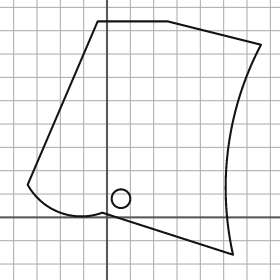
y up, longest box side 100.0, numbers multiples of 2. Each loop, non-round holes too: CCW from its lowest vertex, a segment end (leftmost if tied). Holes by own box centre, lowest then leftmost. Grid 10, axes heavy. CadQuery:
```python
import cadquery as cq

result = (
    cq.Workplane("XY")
    .moveTo(54.0, -16.0)
    .threePointArc((52.0, 30.0), (66.0, 74.0))
    .lineTo(26.0, 84.0)
    .lineTo(-4.0, 84.0)
    .lineTo(-34.0, 14.0)
    .threePointArc((-20.0, 2.0), (-2.0, 2.0))
    .close()
    .moveTo(6.0, 8.0)
    .circle(4.0)
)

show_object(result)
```